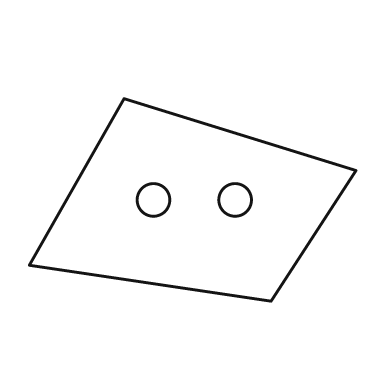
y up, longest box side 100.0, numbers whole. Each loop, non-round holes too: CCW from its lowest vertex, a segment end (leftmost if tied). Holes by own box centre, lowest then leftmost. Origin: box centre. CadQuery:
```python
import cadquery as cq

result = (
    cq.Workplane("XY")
    .moveTo(24.0, -31.0)
    .lineTo(50.0, 9.0)
    .lineTo(-21.0, 31.0)
    .lineTo(-50.0, -20.0)
    .close()
    .moveTo(-12.0, 0.0)
    .circle(5.0)
    .moveTo(13.0, 0.0)
    .circle(5.0)
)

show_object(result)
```